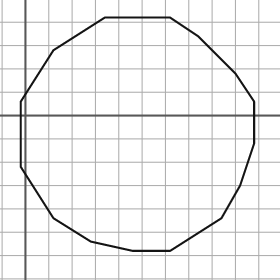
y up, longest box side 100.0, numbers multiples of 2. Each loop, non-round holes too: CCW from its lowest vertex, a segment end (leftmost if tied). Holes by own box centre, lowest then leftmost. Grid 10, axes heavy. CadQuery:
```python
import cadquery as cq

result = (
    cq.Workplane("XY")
    .moveTo(46.0, -58.0)
    .lineTo(62.0, -58.0)
    .lineTo(84.0, -44.0)
    .lineTo(92.0, -30.0)
    .lineTo(98.0, -12.0)
    .lineTo(98.0, 6.0)
    .lineTo(90.0, 18.0)
    .lineTo(74.0, 34.0)
    .lineTo(62.0, 42.0)
    .lineTo(34.0, 42.0)
    .lineTo(12.0, 28.0)
    .lineTo(-2.0, 6.0)
    .lineTo(-2.0, -22.0)
    .lineTo(12.0, -44.0)
    .lineTo(28.0, -54.0)
    .close()
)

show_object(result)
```